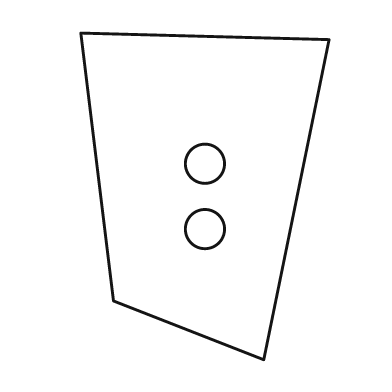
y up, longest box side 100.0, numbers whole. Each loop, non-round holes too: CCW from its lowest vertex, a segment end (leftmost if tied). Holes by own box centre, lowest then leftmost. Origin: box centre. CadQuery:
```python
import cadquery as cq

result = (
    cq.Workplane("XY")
    .moveTo(18.0, -50.0)
    .lineTo(38.0, 48.0)
    .lineTo(-38.0, 50.0)
    .lineTo(-28.0, -32.0)
    .close()
    .moveTo(0.0, -10.0)
    .circle(6.0)
    .moveTo(0.0, 10.0)
    .circle(6.0)
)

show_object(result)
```